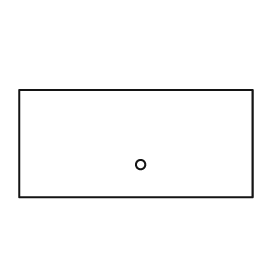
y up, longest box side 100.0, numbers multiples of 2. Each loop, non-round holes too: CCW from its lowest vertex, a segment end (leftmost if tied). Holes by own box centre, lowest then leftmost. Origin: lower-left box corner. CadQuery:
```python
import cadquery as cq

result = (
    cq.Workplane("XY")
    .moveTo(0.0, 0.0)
    .lineTo(100.0, 0.0)
    .lineTo(100.0, 46.0)
    .lineTo(0.0, 46.0)
    .close()
    .moveTo(52.0, 14.0)
    .circle(2.0)
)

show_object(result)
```